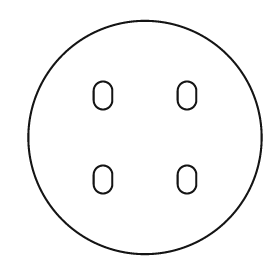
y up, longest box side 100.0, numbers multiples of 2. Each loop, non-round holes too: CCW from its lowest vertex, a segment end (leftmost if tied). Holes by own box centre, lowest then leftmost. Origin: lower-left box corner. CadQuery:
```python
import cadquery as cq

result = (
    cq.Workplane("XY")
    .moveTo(50.0, 50.0)
    .circle(50.0)
    .moveTo(28.0, 30.0)
    .threePointArc((32.0, 26.0), (36.0, 30.0))
    .lineTo(36.0, 34.0)
    .threePointArc((32.0, 38.0), (28.0, 34.0))
    .close()
    .moveTo(64.0, 30.0)
    .threePointArc((68.0, 26.0), (72.0, 30.0))
    .lineTo(72.0, 34.0)
    .threePointArc((68.0, 38.0), (64.0, 34.0))
    .close()
    .moveTo(28.0, 66.0)
    .threePointArc((32.0, 62.0), (36.0, 66.0))
    .lineTo(36.0, 70.0)
    .threePointArc((32.0, 74.0), (28.0, 70.0))
    .close()
    .moveTo(64.0, 66.0)
    .threePointArc((68.0, 62.0), (72.0, 66.0))
    .lineTo(72.0, 70.0)
    .threePointArc((68.0, 74.0), (64.0, 70.0))
    .close()
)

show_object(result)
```